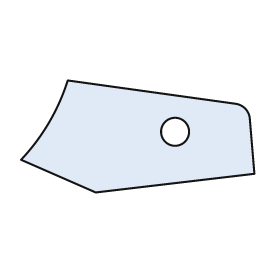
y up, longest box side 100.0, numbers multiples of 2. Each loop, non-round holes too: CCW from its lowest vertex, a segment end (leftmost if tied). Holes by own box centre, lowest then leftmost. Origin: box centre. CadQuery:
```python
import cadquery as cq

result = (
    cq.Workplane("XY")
    .moveTo(-18.0, -24.0)
    .lineTo(50.0, -16.0)
    .lineTo(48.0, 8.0)
    .threePointArc((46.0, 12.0), (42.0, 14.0))
    .lineTo(-30.0, 24.0)
    .threePointArc((-38.0, 6.0), (-50.0, -10.0))
    .close()
    .moveTo(16.0, 2.0)
    .circle(6.0)
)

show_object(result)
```